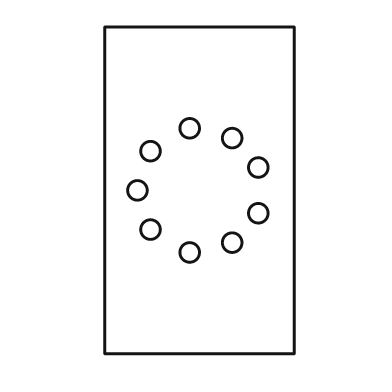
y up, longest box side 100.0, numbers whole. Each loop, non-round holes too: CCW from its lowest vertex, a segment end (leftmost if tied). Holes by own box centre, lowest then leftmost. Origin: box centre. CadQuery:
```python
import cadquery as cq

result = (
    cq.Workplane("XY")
    .moveTo(-29.0, -50.0)
    .lineTo(29.0, -50.0)
    .lineTo(29.0, 50.0)
    .lineTo(-29.0, 50.0)
    .close()
    .moveTo(-3.0, -19.0)
    .circle(3.0)
    .moveTo(10.0, -16.0)
    .circle(3.0)
    .moveTo(-15.0, -12.0)
    .circle(3.0)
    .moveTo(18.0, -7.0)
    .circle(3.0)
    .moveTo(-19.0, 0.0)
    .circle(3.0)
    .moveTo(18.0, 7.0)
    .circle(3.0)
    .moveTo(-15.0, 12.0)
    .circle(3.0)
    .moveTo(10.0, 16.0)
    .circle(3.0)
    .moveTo(-3.0, 19.0)
    .circle(3.0)
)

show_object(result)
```